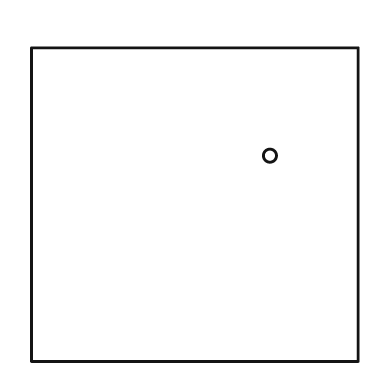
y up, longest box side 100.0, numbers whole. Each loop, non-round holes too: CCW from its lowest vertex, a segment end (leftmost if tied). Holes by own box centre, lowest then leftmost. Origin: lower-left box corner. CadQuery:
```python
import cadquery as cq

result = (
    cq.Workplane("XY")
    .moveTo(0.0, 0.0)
    .lineTo(100.0, 0.0)
    .lineTo(100.0, 96.0)
    .lineTo(0.0, 96.0)
    .close()
    .moveTo(73.0, 63.0)
    .circle(2.0)
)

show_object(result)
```